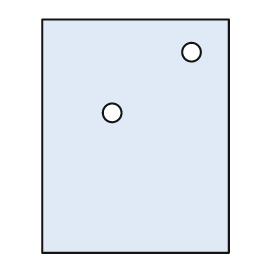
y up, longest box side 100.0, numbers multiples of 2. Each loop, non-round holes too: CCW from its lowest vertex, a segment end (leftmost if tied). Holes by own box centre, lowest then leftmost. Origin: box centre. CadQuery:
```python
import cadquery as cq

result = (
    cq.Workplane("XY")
    .moveTo(-40.0, -50.0)
    .lineTo(40.0, -50.0)
    .lineTo(40.0, 50.0)
    .lineTo(-40.0, 50.0)
    .close()
    .moveTo(-10.0, 10.0)
    .circle(4.0)
    .moveTo(24.0, 36.0)
    .circle(4.0)
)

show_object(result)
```